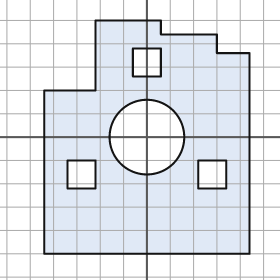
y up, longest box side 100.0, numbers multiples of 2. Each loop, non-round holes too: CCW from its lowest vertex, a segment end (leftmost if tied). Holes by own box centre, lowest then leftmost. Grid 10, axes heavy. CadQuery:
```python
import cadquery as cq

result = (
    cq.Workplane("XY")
    .moveTo(-44.0, -50.0)
    .lineTo(44.0, -50.0)
    .lineTo(44.0, 36.0)
    .lineTo(30.0, 36.0)
    .lineTo(30.0, 44.0)
    .lineTo(6.0, 44.0)
    .lineTo(6.0, 50.0)
    .lineTo(-22.0, 50.0)
    .lineTo(-22.0, 20.0)
    .lineTo(-44.0, 20.0)
    .close()
    .moveTo(-34.0, -22.0)
    .lineTo(-22.0, -22.0)
    .lineTo(-22.0, -10.0)
    .lineTo(-34.0, -10.0)
    .close()
    .moveTo(22.0, -22.0)
    .lineTo(34.0, -22.0)
    .lineTo(34.0, -10.0)
    .lineTo(22.0, -10.0)
    .close()
    .moveTo(0.0, 0.0)
    .circle(16.0)
    .moveTo(-6.0, 26.0)
    .lineTo(6.0, 26.0)
    .lineTo(6.0, 38.0)
    .lineTo(-6.0, 38.0)
    .close()
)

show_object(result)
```